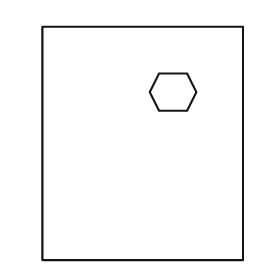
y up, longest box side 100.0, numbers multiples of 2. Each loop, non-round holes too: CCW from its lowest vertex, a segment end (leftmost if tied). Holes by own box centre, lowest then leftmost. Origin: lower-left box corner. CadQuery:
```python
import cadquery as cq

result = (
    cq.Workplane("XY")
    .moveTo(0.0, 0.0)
    .lineTo(86.0, 0.0)
    .lineTo(86.0, 100.0)
    .lineTo(0.0, 100.0)
    .close()
    .moveTo(50.0, 64.0)
    .lineTo(62.0, 64.0)
    .lineTo(66.0, 72.0)
    .lineTo(62.0, 80.0)
    .lineTo(50.0, 80.0)
    .lineTo(46.0, 72.0)
    .close()
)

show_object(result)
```